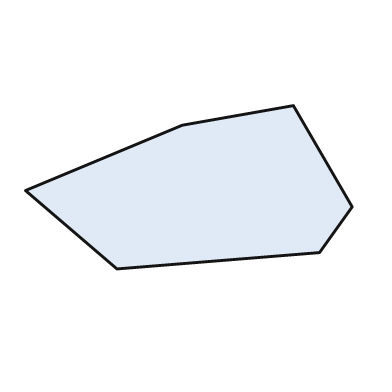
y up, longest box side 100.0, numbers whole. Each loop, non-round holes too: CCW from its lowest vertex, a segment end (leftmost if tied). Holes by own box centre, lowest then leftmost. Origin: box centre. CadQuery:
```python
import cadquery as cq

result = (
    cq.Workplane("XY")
    .moveTo(-22.0, -25.0)
    .lineTo(40.0, -20.0)
    .lineTo(50.0, -6.0)
    .lineTo(32.0, 25.0)
    .lineTo(-2.0, 19.0)
    .lineTo(-50.0, -1.0)
    .close()
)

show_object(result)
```